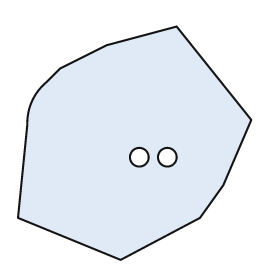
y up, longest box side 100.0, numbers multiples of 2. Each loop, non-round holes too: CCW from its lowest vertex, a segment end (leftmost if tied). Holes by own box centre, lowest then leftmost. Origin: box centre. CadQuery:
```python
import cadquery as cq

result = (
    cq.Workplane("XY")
    .moveTo(-6.0, -50.0)
    .lineTo(28.0, -32.0)
    .lineTo(38.0, -18.0)
    .lineTo(50.0, 10.0)
    .lineTo(18.0, 50.0)
    .lineTo(-12.0, 42.0)
    .lineTo(-32.0, 32.0)
    .lineTo(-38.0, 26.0)
    .threePointArc((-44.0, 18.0), (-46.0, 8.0))
    .lineTo(-50.0, -32.0)
    .close()
    .moveTo(2.0, -6.0)
    .circle(4.0)
    .moveTo(14.0, -6.0)
    .circle(4.0)
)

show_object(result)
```